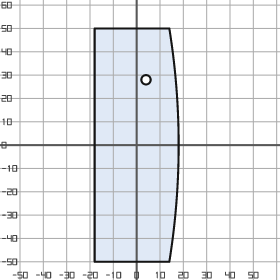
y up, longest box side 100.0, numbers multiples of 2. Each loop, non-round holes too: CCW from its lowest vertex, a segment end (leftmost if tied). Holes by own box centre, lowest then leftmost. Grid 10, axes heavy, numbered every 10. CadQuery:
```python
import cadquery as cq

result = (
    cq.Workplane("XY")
    .moveTo(-18.0, -50.0)
    .lineTo(14.0, -50.0)
    .threePointArc((18.0, 0.0), (14.0, 50.0))
    .lineTo(-18.0, 50.0)
    .close()
    .moveTo(4.0, 28.0)
    .circle(2.0)
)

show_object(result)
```